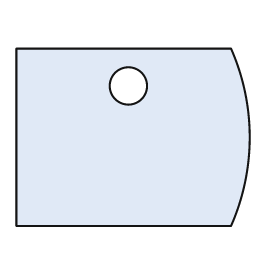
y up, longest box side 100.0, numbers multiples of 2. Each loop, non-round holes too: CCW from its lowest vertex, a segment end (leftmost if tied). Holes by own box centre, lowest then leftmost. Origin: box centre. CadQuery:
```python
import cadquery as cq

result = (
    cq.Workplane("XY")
    .moveTo(-50.0, -38.0)
    .lineTo(42.0, -38.0)
    .threePointArc((50.0, 0.0), (42.0, 38.0))
    .lineTo(-50.0, 38.0)
    .close()
    .moveTo(-2.0, 22.0)
    .circle(8.0)
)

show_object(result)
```